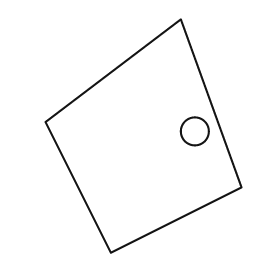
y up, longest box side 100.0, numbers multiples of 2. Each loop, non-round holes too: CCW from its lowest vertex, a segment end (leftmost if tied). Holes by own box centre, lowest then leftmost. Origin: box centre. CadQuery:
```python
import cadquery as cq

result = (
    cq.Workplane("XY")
    .moveTo(-14.0, -50.0)
    .lineTo(42.0, -22.0)
    .lineTo(16.0, 50.0)
    .lineTo(-42.0, 6.0)
    .close()
    .moveTo(22.0, 2.0)
    .circle(6.0)
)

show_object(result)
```